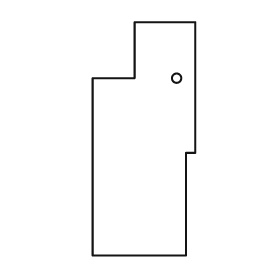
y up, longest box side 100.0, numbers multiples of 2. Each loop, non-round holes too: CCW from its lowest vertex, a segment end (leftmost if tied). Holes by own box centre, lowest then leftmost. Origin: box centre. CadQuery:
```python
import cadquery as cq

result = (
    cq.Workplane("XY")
    .moveTo(-22.0, -50.0)
    .lineTo(18.0, -50.0)
    .lineTo(18.0, -6.0)
    .lineTo(22.0, -6.0)
    .lineTo(22.0, 50.0)
    .lineTo(-4.0, 50.0)
    .lineTo(-4.0, 26.0)
    .lineTo(-22.0, 26.0)
    .close()
    .moveTo(14.0, 26.0)
    .circle(2.0)
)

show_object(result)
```